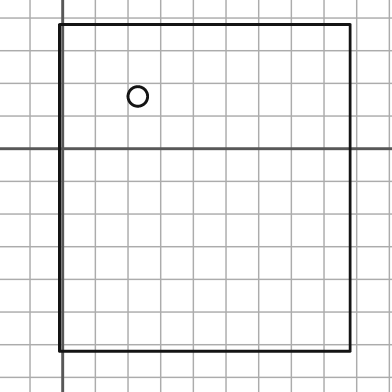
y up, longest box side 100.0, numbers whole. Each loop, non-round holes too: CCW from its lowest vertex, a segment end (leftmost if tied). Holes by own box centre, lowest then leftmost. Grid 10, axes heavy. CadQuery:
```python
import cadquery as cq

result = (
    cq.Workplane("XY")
    .moveTo(-1.0, -62.0)
    .lineTo(88.0, -62.0)
    .lineTo(88.0, 38.0)
    .lineTo(-1.0, 38.0)
    .close()
    .moveTo(23.0, 16.0)
    .circle(3.0)
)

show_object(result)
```